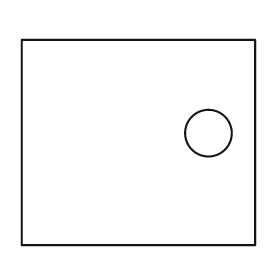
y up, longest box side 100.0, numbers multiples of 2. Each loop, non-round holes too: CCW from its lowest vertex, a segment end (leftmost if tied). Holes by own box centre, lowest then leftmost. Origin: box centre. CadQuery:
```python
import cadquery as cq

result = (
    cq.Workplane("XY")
    .moveTo(-50.0, -44.0)
    .lineTo(50.0, -44.0)
    .lineTo(50.0, 44.0)
    .lineTo(-50.0, 44.0)
    .close()
    .moveTo(30.0, 4.0)
    .circle(10.0)
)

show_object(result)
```